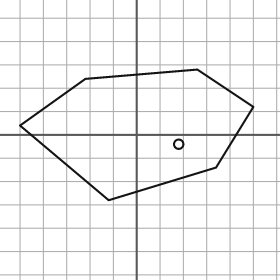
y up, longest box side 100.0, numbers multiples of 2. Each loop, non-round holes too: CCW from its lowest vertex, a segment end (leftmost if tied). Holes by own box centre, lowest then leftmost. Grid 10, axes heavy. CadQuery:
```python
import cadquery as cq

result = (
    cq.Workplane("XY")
    .moveTo(-12.0, -28.0)
    .lineTo(34.0, -14.0)
    .lineTo(50.0, 12.0)
    .lineTo(26.0, 28.0)
    .lineTo(-22.0, 24.0)
    .lineTo(-50.0, 4.0)
    .close()
    .moveTo(18.0, -4.0)
    .circle(2.0)
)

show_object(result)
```